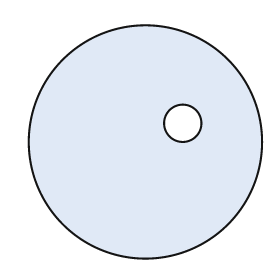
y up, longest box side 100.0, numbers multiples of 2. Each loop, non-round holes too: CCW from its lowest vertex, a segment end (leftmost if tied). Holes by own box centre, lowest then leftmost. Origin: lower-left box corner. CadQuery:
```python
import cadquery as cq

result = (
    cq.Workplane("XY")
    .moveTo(50.0, 50.0)
    .circle(50.0)
    .moveTo(66.0, 58.0)
    .circle(8.0)
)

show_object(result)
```